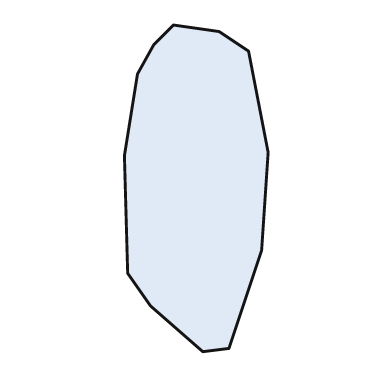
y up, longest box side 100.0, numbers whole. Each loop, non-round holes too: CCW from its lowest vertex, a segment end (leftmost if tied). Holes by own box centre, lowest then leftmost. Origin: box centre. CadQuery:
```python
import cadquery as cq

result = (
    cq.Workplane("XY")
    .moveTo(2.0, -50.0)
    .lineTo(10.0, -49.0)
    .lineTo(20.0, -19.0)
    .lineTo(22.0, 11.0)
    .lineTo(16.0, 42.0)
    .lineTo(7.0, 48.0)
    .lineTo(-7.0, 50.0)
    .lineTo(-13.0, 44.0)
    .lineTo(-18.0, 35.0)
    .lineTo(-22.0, 10.0)
    .lineTo(-21.0, -26.0)
    .lineTo(-14.0, -36.0)
    .close()
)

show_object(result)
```